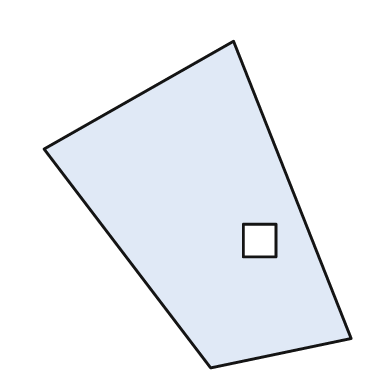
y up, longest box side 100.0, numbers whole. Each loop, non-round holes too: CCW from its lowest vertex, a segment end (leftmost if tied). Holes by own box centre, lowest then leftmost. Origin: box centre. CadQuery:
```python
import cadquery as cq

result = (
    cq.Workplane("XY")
    .moveTo(4.0, -50.0)
    .lineTo(47.0, -41.0)
    .lineTo(11.0, 50.0)
    .lineTo(-47.0, 17.0)
    .close()
    .moveTo(14.0, -16.0)
    .lineTo(24.0, -16.0)
    .lineTo(24.0, -6.0)
    .lineTo(14.0, -6.0)
    .close()
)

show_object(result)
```